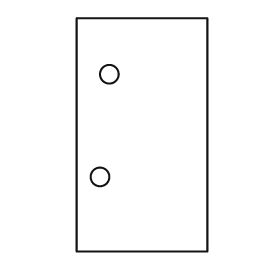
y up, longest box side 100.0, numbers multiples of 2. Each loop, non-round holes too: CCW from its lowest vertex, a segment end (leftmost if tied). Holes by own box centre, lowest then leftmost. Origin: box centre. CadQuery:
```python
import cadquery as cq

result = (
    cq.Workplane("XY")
    .moveTo(-28.0, -50.0)
    .lineTo(28.0, -50.0)
    .lineTo(28.0, 50.0)
    .lineTo(-28.0, 50.0)
    .close()
    .moveTo(-18.0, -18.0)
    .circle(4.0)
    .moveTo(-14.0, 26.0)
    .circle(4.0)
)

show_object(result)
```